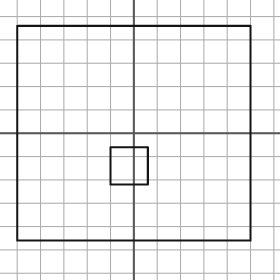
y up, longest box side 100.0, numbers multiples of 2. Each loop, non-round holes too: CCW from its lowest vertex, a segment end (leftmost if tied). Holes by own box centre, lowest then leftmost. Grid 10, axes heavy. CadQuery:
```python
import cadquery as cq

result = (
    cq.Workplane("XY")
    .moveTo(-50.0, -46.0)
    .lineTo(50.0, -46.0)
    .lineTo(50.0, 46.0)
    .lineTo(-50.0, 46.0)
    .close()
    .moveTo(-10.0, -22.0)
    .lineTo(6.0, -22.0)
    .lineTo(6.0, -6.0)
    .lineTo(-10.0, -6.0)
    .close()
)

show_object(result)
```